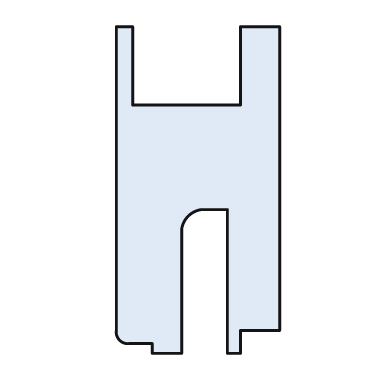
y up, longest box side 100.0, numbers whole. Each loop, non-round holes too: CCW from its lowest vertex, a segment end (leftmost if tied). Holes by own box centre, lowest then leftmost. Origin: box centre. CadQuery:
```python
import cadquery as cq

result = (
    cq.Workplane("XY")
    .moveTo(-14.0, -50.0)
    .lineTo(-5.0, -50.0)
    .lineTo(-5.0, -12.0)
    .threePointArc((-3.0, -8.0), (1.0, -6.0))
    .lineTo(9.0, -6.0)
    .lineTo(9.0, -50.0)
    .lineTo(13.0, -50.0)
    .lineTo(13.0, -43.0)
    .lineTo(25.0, -43.0)
    .lineTo(25.0, 50.0)
    .lineTo(13.0, 50.0)
    .lineTo(13.0, 26.0)
    .lineTo(-20.0, 26.0)
    .lineTo(-20.0, 50.0)
    .lineTo(-25.0, 50.0)
    .lineTo(-25.0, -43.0)
    .threePointArc((-24.0, -46.0), (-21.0, -47.0))
    .lineTo(-14.0, -47.0)
    .close()
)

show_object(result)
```